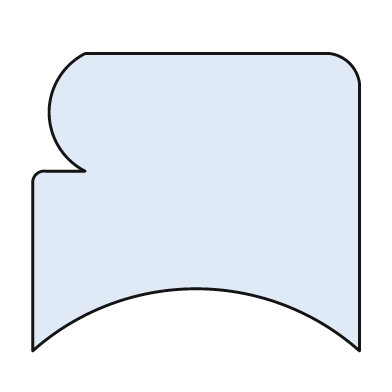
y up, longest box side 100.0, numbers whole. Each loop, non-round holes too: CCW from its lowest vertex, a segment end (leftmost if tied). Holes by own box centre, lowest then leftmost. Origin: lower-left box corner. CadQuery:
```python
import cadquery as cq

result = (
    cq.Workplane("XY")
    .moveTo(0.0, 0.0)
    .threePointArc((50.0, 19.0), (100.0, 0.0))
    .lineTo(100.0, 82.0)
    .threePointArc((97.0, 88.0), (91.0, 91.0))
    .lineTo(16.0, 91.0)
    .threePointArc((5.0, 73.0), (16.0, 55.0))
    .lineTo(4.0, 55.0)
    .threePointArc((1.0, 54.0), (0.0, 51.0))
    .close()
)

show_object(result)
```